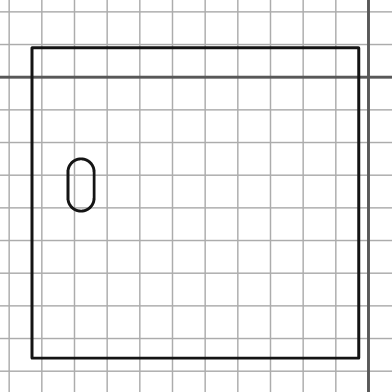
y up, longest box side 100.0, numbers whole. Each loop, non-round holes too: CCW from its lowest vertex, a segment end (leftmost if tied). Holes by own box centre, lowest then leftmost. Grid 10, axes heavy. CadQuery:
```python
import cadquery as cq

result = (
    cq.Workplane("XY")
    .moveTo(-103.0, -86.0)
    .lineTo(-3.0, -86.0)
    .lineTo(-3.0, 9.0)
    .lineTo(-103.0, 9.0)
    .close()
    .moveTo(-92.0, -37.0)
    .threePointArc((-88.0, -41.0), (-84.0, -37.0))
    .lineTo(-84.0, -29.0)
    .threePointArc((-88.0, -25.0), (-92.0, -29.0))
    .close()
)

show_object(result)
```